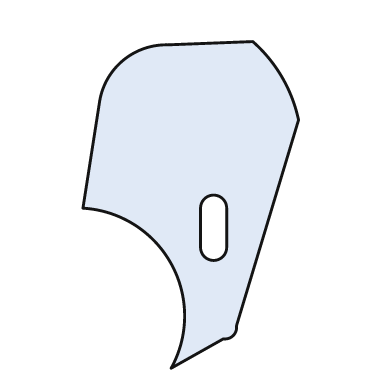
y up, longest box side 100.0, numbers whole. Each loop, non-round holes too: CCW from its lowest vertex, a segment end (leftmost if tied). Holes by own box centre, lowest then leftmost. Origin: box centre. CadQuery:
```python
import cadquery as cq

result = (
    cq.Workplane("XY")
    .moveTo(-6.0, -50.0)
    .lineTo(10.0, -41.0)
    .threePointArc((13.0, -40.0), (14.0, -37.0))
    .lineTo(33.0, 26.0)
    .threePointArc((28.0, 39.0), (19.0, 50.0))
    .lineTo(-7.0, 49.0)
    .threePointArc((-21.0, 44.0), (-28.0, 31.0))
    .lineTo(-33.0, -1.0)
    .threePointArc((-6.0, -18.0), (-6.0, -50.0))
    .close()
    .moveTo(3.0, -13.0)
    .threePointArc((7.0, -17.0), (11.0, -13.0))
    .lineTo(11.0, -1.0)
    .threePointArc((7.0, 3.0), (3.0, -1.0))
    .close()
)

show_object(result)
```